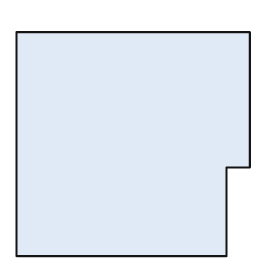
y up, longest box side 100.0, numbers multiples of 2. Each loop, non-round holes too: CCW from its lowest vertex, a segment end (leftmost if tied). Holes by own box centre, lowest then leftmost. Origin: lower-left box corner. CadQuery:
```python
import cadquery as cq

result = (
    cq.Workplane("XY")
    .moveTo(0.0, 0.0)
    .lineTo(90.0, 0.0)
    .lineTo(90.0, 38.0)
    .lineTo(100.0, 38.0)
    .lineTo(100.0, 96.0)
    .lineTo(0.0, 96.0)
    .close()
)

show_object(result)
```